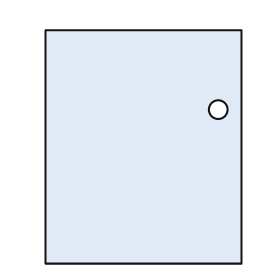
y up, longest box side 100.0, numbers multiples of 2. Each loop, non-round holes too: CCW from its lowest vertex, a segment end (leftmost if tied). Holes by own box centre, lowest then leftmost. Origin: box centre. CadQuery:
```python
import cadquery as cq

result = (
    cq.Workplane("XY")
    .moveTo(-42.0, -50.0)
    .lineTo(42.0, -50.0)
    .lineTo(42.0, 50.0)
    .lineTo(-42.0, 50.0)
    .close()
    .moveTo(32.0, 16.0)
    .circle(4.0)
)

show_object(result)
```